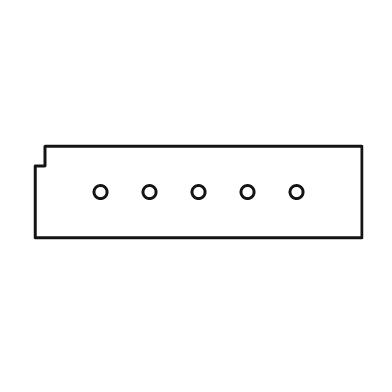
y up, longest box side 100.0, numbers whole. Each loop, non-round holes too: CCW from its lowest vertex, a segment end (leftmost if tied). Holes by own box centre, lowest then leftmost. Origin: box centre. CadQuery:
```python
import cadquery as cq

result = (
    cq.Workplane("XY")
    .moveTo(-50.0, -14.0)
    .lineTo(50.0, -14.0)
    .lineTo(50.0, 14.0)
    .lineTo(-47.0, 14.0)
    .lineTo(-47.0, 8.0)
    .lineTo(-50.0, 8.0)
    .close()
    .moveTo(-30.0, 0.0)
    .circle(2.0)
    .moveTo(-15.0, 0.0)
    .circle(2.0)
    .moveTo(0.0, 0.0)
    .circle(2.0)
    .moveTo(15.0, 0.0)
    .circle(2.0)
    .moveTo(30.0, 0.0)
    .circle(2.0)
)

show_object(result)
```